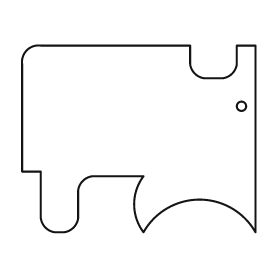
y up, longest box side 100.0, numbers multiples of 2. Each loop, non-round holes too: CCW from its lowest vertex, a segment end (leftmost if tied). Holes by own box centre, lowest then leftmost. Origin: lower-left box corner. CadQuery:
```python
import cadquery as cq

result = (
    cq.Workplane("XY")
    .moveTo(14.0, 0.0)
    .lineTo(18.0, 0.0)
    .threePointArc((22.0, 2.0), (24.0, 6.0))
    .lineTo(24.0, 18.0)
    .threePointArc((26.0, 22.0), (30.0, 24.0))
    .lineTo(52.0, 24.0)
    .threePointArc((48.0, 12.0), (52.0, 0.0))
    .threePointArc((76.0, 14.0), (100.0, 0.0))
    .lineTo(100.0, 80.0)
    .lineTo(92.0, 80.0)
    .lineTo(92.0, 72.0)
    .threePointArc((90.0, 68.0), (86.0, 66.0))
    .lineTo(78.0, 66.0)
    .threePointArc((74.0, 68.0), (72.0, 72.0))
    .lineTo(72.0, 80.0)
    .lineTo(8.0, 80.0)
    .threePointArc((2.0, 78.0), (0.0, 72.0))
    .lineTo(0.0, 26.0)
    .lineTo(8.0, 26.0)
    .lineTo(8.0, 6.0)
    .threePointArc((10.0, 2.0), (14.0, 0.0))
    .close()
    .moveTo(94.0, 54.0)
    .circle(2.0)
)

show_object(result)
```